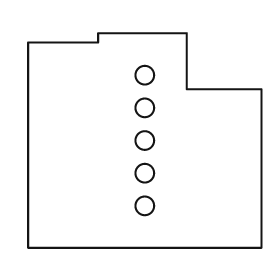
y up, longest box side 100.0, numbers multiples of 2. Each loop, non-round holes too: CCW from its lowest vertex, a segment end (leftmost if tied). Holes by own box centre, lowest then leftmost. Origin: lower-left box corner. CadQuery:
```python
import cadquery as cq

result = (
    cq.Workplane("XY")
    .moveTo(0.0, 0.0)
    .lineTo(100.0, 0.0)
    .lineTo(100.0, 68.0)
    .lineTo(68.0, 68.0)
    .lineTo(68.0, 92.0)
    .lineTo(30.0, 92.0)
    .lineTo(30.0, 88.0)
    .lineTo(0.0, 88.0)
    .close()
    .moveTo(50.0, 18.0)
    .circle(4.0)
    .moveTo(50.0, 32.0)
    .circle(4.0)
    .moveTo(50.0, 46.0)
    .circle(4.0)
    .moveTo(50.0, 60.0)
    .circle(4.0)
    .moveTo(50.0, 74.0)
    .circle(4.0)
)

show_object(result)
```